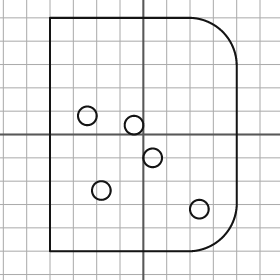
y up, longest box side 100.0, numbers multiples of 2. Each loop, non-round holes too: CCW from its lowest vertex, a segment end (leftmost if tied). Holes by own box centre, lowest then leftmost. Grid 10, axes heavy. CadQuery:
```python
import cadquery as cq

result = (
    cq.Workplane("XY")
    .moveTo(-40.0, -50.0)
    .lineTo(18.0, -50.0)
    .threePointArc((34.0, -44.0), (40.0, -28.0))
    .lineTo(40.0, 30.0)
    .threePointArc((34.0, 44.0), (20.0, 50.0))
    .lineTo(-40.0, 50.0)
    .close()
    .moveTo(24.0, -32.0)
    .circle(4.0)
    .moveTo(-18.0, -24.0)
    .circle(4.0)
    .moveTo(4.0, -10.0)
    .circle(4.0)
    .moveTo(-4.0, 4.0)
    .circle(4.0)
    .moveTo(-24.0, 8.0)
    .circle(4.0)
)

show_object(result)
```